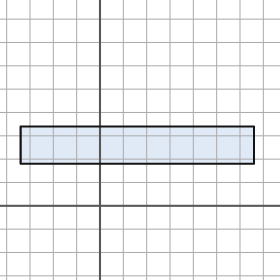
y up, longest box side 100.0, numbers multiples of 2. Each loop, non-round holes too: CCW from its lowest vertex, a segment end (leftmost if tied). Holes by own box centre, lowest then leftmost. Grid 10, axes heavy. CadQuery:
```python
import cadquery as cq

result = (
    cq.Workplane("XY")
    .moveTo(-34.0, 18.0)
    .lineTo(66.0, 18.0)
    .lineTo(66.0, 34.0)
    .lineTo(-34.0, 34.0)
    .close()
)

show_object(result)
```